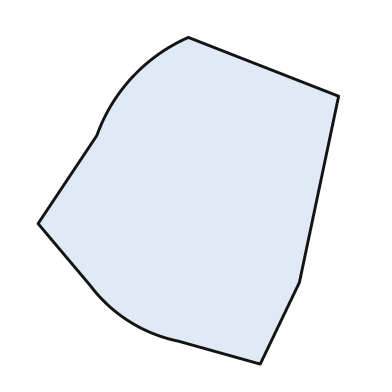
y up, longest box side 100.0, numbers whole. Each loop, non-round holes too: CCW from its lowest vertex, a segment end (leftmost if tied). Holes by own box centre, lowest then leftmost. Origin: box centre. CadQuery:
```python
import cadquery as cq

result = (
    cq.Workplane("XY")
    .moveTo(22.0, -50.0)
    .lineTo(34.0, -25.0)
    .lineTo(46.0, 32.0)
    .lineTo(0.0, 50.0)
    .threePointArc((-17.0, 38.0), (-28.0, 20.0))
    .lineTo(-46.0, -7.0)
    .lineTo(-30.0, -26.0)
    .threePointArc((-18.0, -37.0), (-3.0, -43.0))
    .close()
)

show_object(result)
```